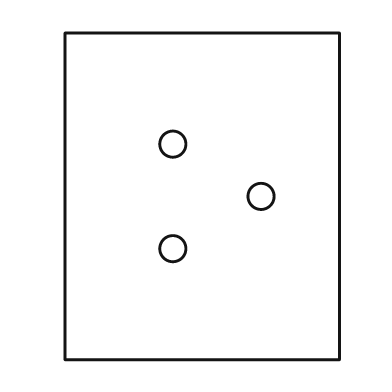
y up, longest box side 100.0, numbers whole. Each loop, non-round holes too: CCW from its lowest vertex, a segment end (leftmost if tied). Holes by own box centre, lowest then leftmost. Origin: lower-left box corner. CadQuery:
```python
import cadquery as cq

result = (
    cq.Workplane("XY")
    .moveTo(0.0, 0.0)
    .lineTo(84.0, 0.0)
    .lineTo(84.0, 100.0)
    .lineTo(0.0, 100.0)
    .close()
    .moveTo(33.0, 34.0)
    .circle(4.0)
    .moveTo(60.0, 50.0)
    .circle(4.0)
    .moveTo(33.0, 66.0)
    .circle(4.0)
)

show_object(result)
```